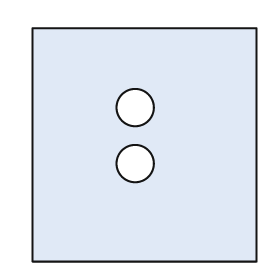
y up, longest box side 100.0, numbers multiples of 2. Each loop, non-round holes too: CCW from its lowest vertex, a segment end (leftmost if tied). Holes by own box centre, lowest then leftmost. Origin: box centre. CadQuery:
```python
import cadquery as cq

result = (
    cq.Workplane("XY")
    .moveTo(-48.0, -50.0)
    .lineTo(48.0, -50.0)
    .lineTo(48.0, 50.0)
    .lineTo(-48.0, 50.0)
    .close()
    .moveTo(-4.0, -8.0)
    .circle(8.0)
    .moveTo(-4.0, 16.0)
    .circle(8.0)
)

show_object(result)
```